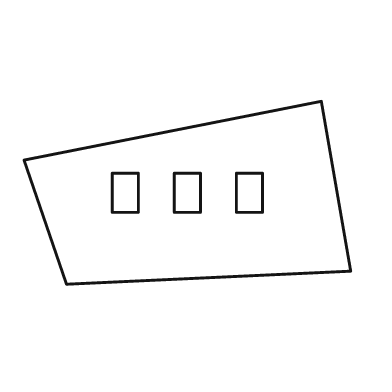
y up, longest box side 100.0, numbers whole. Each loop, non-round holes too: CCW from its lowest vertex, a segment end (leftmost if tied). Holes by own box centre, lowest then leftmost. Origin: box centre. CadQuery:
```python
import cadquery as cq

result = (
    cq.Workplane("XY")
    .moveTo(-37.0, -28.0)
    .lineTo(50.0, -24.0)
    .lineTo(41.0, 28.0)
    .lineTo(-50.0, 10.0)
    .close()
    .moveTo(-23.0, -6.0)
    .lineTo(-15.0, -6.0)
    .lineTo(-15.0, 6.0)
    .lineTo(-23.0, 6.0)
    .close()
    .moveTo(-4.0, -6.0)
    .lineTo(4.0, -6.0)
    .lineTo(4.0, 6.0)
    .lineTo(-4.0, 6.0)
    .close()
    .moveTo(15.0, -6.0)
    .lineTo(23.0, -6.0)
    .lineTo(23.0, 6.0)
    .lineTo(15.0, 6.0)
    .close()
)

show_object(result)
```